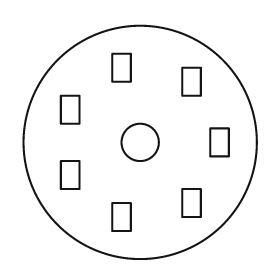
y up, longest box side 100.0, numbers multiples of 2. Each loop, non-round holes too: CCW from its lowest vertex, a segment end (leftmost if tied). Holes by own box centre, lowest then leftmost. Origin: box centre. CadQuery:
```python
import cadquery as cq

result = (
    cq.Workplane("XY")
    .moveTo(0.0, 0.0)
    .circle(50.0)
    .moveTo(-12.0, -38.0)
    .lineTo(-4.0, -38.0)
    .lineTo(-4.0, -26.0)
    .lineTo(-12.0, -26.0)
    .close()
    .moveTo(18.0, -32.0)
    .lineTo(26.0, -32.0)
    .lineTo(26.0, -20.0)
    .lineTo(18.0, -20.0)
    .close()
    .moveTo(-34.0, -20.0)
    .lineTo(-26.0, -20.0)
    .lineTo(-26.0, -8.0)
    .lineTo(-34.0, -8.0)
    .close()
    .moveTo(0.0, 0.0)
    .circle(8.0)
    .moveTo(30.0, -6.0)
    .lineTo(38.0, -6.0)
    .lineTo(38.0, 6.0)
    .lineTo(30.0, 6.0)
    .close()
    .moveTo(-34.0, 8.0)
    .lineTo(-26.0, 8.0)
    .lineTo(-26.0, 20.0)
    .lineTo(-34.0, 20.0)
    .close()
    .moveTo(18.0, 20.0)
    .lineTo(26.0, 20.0)
    .lineTo(26.0, 32.0)
    .lineTo(18.0, 32.0)
    .close()
    .moveTo(-12.0, 26.0)
    .lineTo(-4.0, 26.0)
    .lineTo(-4.0, 38.0)
    .lineTo(-12.0, 38.0)
    .close()
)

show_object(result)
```